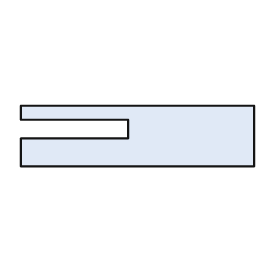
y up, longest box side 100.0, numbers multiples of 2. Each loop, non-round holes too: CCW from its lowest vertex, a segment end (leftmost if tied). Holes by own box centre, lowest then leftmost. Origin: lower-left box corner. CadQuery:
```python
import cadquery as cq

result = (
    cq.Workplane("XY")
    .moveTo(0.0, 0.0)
    .lineTo(100.0, 0.0)
    .lineTo(100.0, 26.0)
    .lineTo(0.0, 26.0)
    .lineTo(0.0, 20.0)
    .lineTo(46.0, 20.0)
    .lineTo(46.0, 12.0)
    .lineTo(0.0, 12.0)
    .close()
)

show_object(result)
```